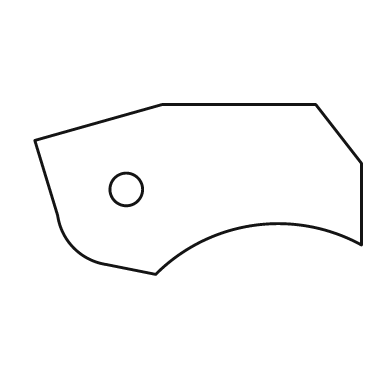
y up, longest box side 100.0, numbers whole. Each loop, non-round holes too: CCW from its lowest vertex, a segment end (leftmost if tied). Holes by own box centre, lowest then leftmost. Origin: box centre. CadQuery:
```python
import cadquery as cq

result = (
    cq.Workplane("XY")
    .moveTo(-13.0, -26.0)
    .threePointArc((17.0, -11.0), (50.0, -17.0))
    .lineTo(50.0, 8.0)
    .lineTo(36.0, 26.0)
    .lineTo(-11.0, 26.0)
    .lineTo(-50.0, 15.0)
    .lineTo(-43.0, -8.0)
    .threePointArc((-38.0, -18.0), (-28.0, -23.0))
    .close()
    .moveTo(-22.0, 0.0)
    .circle(5.0)
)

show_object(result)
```